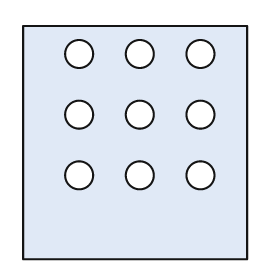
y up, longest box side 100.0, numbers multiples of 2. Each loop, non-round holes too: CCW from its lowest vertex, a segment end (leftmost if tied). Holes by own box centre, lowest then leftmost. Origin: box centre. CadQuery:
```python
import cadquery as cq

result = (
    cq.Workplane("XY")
    .moveTo(-48.0, -50.0)
    .lineTo(48.0, -50.0)
    .lineTo(48.0, 50.0)
    .lineTo(-48.0, 50.0)
    .close()
    .moveTo(-24.0, -14.0)
    .circle(6.0)
    .moveTo(2.0, -14.0)
    .circle(6.0)
    .moveTo(28.0, -14.0)
    .circle(6.0)
    .moveTo(-24.0, 12.0)
    .circle(6.0)
    .moveTo(2.0, 12.0)
    .circle(6.0)
    .moveTo(28.0, 12.0)
    .circle(6.0)
    .moveTo(-24.0, 38.0)
    .circle(6.0)
    .moveTo(2.0, 38.0)
    .circle(6.0)
    .moveTo(28.0, 38.0)
    .circle(6.0)
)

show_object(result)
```